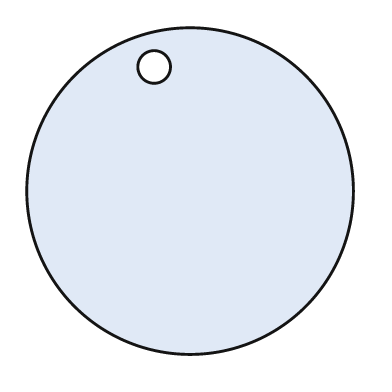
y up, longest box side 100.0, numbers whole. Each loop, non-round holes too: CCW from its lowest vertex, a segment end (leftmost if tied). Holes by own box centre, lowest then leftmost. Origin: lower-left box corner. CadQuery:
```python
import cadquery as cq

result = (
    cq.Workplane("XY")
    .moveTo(50.0, 50.0)
    .circle(50.0)
    .moveTo(39.0, 88.0)
    .circle(5.0)
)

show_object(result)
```